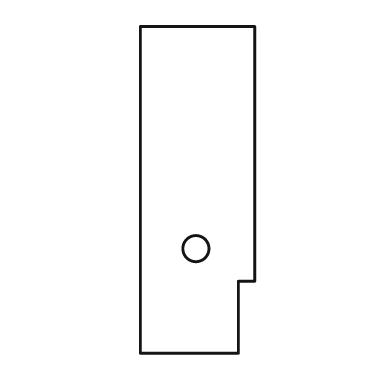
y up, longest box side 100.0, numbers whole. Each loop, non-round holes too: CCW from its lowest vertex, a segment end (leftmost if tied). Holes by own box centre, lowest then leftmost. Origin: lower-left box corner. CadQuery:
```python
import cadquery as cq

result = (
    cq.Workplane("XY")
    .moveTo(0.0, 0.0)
    .lineTo(30.0, 0.0)
    .lineTo(30.0, 22.0)
    .lineTo(35.0, 22.0)
    .lineTo(35.0, 100.0)
    .lineTo(0.0, 100.0)
    .close()
    .moveTo(17.0, 32.0)
    .circle(4.0)
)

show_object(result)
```